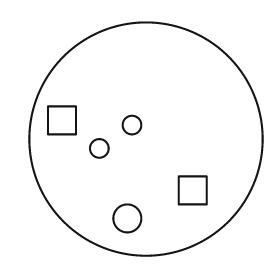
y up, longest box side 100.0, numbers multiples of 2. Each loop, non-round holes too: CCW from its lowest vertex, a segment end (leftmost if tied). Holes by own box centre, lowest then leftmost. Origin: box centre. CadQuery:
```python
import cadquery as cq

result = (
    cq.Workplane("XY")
    .moveTo(0.0, 0.0)
    .circle(50.0)
    .moveTo(-8.0, -34.0)
    .circle(6.0)
    .moveTo(14.0, -28.0)
    .lineTo(26.0, -28.0)
    .lineTo(26.0, -16.0)
    .lineTo(14.0, -16.0)
    .close()
    .moveTo(-20.0, -4.0)
    .circle(4.0)
    .moveTo(-6.0, 6.0)
    .circle(4.0)
    .moveTo(-42.0, 2.0)
    .lineTo(-30.0, 2.0)
    .lineTo(-30.0, 14.0)
    .lineTo(-42.0, 14.0)
    .close()
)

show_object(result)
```